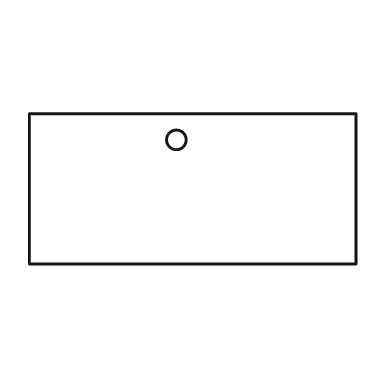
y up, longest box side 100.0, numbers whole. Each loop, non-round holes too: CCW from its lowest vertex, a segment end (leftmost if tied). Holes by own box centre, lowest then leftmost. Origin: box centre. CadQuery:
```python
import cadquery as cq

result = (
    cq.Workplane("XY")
    .moveTo(-50.0, -23.0)
    .lineTo(50.0, -23.0)
    .lineTo(50.0, 23.0)
    .lineTo(-50.0, 23.0)
    .close()
    .moveTo(-5.0, 15.0)
    .circle(3.0)
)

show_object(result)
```